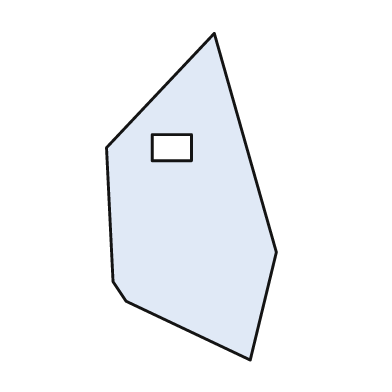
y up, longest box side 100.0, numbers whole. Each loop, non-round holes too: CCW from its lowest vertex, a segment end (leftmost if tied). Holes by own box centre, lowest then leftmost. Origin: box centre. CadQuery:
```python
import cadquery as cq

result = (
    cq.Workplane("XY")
    .moveTo(18.0, -50.0)
    .lineTo(26.0, -17.0)
    .lineTo(7.0, 50.0)
    .lineTo(-26.0, 15.0)
    .lineTo(-24.0, -26.0)
    .lineTo(-20.0, -32.0)
    .close()
    .moveTo(-12.0, 11.0)
    .lineTo(0.0, 11.0)
    .lineTo(0.0, 19.0)
    .lineTo(-12.0, 19.0)
    .close()
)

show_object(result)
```